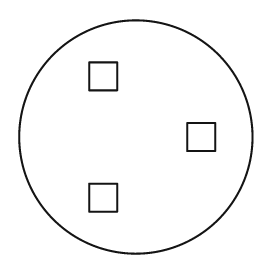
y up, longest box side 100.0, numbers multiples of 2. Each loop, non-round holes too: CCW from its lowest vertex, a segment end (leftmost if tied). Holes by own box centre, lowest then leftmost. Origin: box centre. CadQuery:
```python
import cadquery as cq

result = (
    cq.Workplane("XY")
    .moveTo(0.0, 0.0)
    .circle(50.0)
    .moveTo(-20.0, -32.0)
    .lineTo(-8.0, -32.0)
    .lineTo(-8.0, -20.0)
    .lineTo(-20.0, -20.0)
    .close()
    .moveTo(22.0, -6.0)
    .lineTo(34.0, -6.0)
    .lineTo(34.0, 6.0)
    .lineTo(22.0, 6.0)
    .close()
    .moveTo(-20.0, 20.0)
    .lineTo(-8.0, 20.0)
    .lineTo(-8.0, 32.0)
    .lineTo(-20.0, 32.0)
    .close()
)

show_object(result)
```